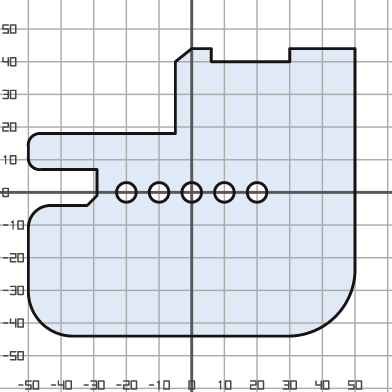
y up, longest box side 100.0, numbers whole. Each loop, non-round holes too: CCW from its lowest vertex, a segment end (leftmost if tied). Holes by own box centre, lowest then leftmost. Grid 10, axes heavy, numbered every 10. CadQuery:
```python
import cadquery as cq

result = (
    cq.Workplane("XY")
    .moveTo(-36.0, -44.0)
    .lineTo(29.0, -44.0)
    .threePointArc((44.0, -38.0), (50.0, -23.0))
    .lineTo(50.0, 44.0)
    .lineTo(30.0, 44.0)
    .lineTo(30.0, 40.0)
    .lineTo(6.0, 40.0)
    .lineTo(6.0, 44.0)
    .lineTo(0.0, 44.0)
    .lineTo(-5.0, 40.0)
    .lineTo(-5.0, 18.0)
    .lineTo(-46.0, 18.0)
    .threePointArc((-49.0, 17.0), (-50.0, 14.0))
    .lineTo(-50.0, 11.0)
    .threePointArc((-49.0, 8.0), (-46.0, 7.0))
    .lineTo(-29.0, 7.0)
    .lineTo(-29.0, -1.0)
    .lineTo(-32.0, -4.0)
    .lineTo(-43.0, -4.0)
    .threePointArc((-48.0, -6.0), (-50.0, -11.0))
    .lineTo(-50.0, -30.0)
    .threePointArc((-46.0, -40.0), (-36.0, -44.0))
    .close()
    .moveTo(-20.0, 0.0)
    .circle(3.0)
    .moveTo(-10.0, 0.0)
    .circle(3.0)
    .moveTo(0.0, 0.0)
    .circle(3.0)
    .moveTo(10.0, 0.0)
    .circle(3.0)
    .moveTo(20.0, 0.0)
    .circle(3.0)
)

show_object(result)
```